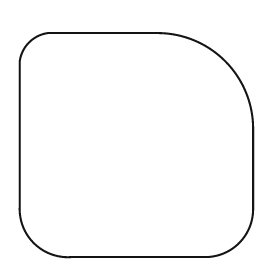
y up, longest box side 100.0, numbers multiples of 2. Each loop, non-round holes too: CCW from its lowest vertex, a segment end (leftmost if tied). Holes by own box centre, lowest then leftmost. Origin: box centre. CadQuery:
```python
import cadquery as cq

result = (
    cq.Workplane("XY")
    .moveTo(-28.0, -48.0)
    .lineTo(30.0, -48.0)
    .threePointArc((44.0, -42.0), (50.0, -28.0))
    .lineTo(50.0, 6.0)
    .threePointArc((38.0, 36.0), (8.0, 48.0))
    .lineTo(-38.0, 48.0)
    .threePointArc((-46.0, 44.0), (-50.0, 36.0))
    .lineTo(-50.0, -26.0)
    .threePointArc((-44.0, -42.0), (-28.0, -48.0))
    .close()
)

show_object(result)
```